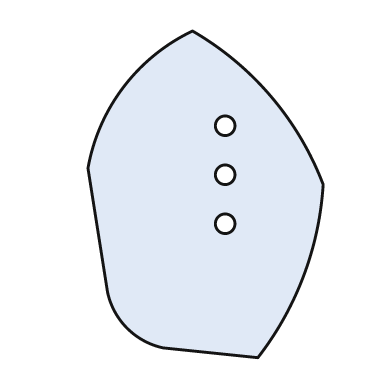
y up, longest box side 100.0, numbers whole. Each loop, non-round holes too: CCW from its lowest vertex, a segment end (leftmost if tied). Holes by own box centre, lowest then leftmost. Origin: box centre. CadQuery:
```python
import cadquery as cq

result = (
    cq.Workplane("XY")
    .moveTo(16.0, -50.0)
    .threePointArc((30.0, -25.0), (36.0, 3.0))
    .threePointArc((20.0, 30.0), (-4.0, 50.0))
    .threePointArc((-25.0, 33.0), (-36.0, 8.0))
    .lineTo(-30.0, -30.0)
    .threePointArc((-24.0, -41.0), (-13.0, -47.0))
    .close()
    .moveTo(6.0, -9.0)
    .circle(3.0)
    .moveTo(6.0, 6.0)
    .circle(3.0)
    .moveTo(6.0, 21.0)
    .circle(3.0)
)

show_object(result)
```